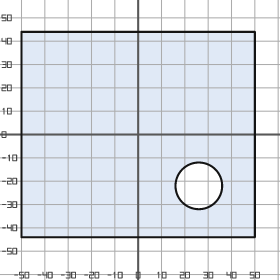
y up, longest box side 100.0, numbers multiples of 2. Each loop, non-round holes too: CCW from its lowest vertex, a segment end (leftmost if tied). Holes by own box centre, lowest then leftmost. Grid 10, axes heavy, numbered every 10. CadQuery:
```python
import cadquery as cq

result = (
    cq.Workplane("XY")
    .moveTo(-50.0, -44.0)
    .lineTo(50.0, -44.0)
    .lineTo(50.0, 44.0)
    .lineTo(-50.0, 44.0)
    .close()
    .moveTo(26.0, -22.0)
    .circle(10.0)
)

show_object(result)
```